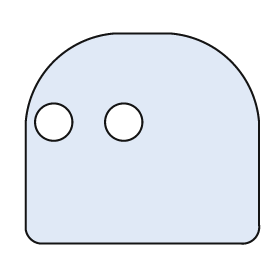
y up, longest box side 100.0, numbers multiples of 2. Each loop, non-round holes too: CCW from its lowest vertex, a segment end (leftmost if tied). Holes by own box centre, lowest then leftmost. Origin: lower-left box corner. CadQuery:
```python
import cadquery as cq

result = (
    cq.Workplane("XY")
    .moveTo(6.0, 0.0)
    .lineTo(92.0, 0.0)
    .threePointArc((98.0, 2.0), (100.0, 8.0))
    .lineTo(100.0, 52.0)
    .threePointArc((88.0, 78.0), (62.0, 90.0))
    .lineTo(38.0, 90.0)
    .threePointArc((12.0, 78.0), (0.0, 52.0))
    .lineTo(0.0, 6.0)
    .threePointArc((2.0, 2.0), (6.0, 0.0))
    .close()
    .moveTo(12.0, 52.0)
    .circle(8.0)
    .moveTo(42.0, 52.0)
    .circle(8.0)
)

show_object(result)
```